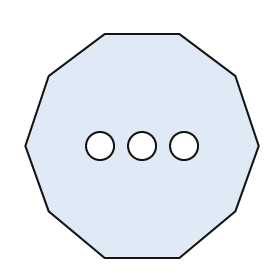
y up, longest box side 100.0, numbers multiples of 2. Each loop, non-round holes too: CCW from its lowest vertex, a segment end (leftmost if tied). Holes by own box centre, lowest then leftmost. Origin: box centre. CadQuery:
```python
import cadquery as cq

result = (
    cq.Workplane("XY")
    .moveTo(-16.0, -48.0)
    .lineTo(16.0, -48.0)
    .lineTo(40.0, -28.0)
    .lineTo(50.0, 0.0)
    .lineTo(40.0, 30.0)
    .lineTo(16.0, 48.0)
    .lineTo(-16.0, 48.0)
    .lineTo(-40.0, 30.0)
    .lineTo(-50.0, 0.0)
    .lineTo(-40.0, -28.0)
    .close()
    .moveTo(-18.0, 0.0)
    .circle(6.0)
    .moveTo(0.0, 0.0)
    .circle(6.0)
    .moveTo(18.0, 0.0)
    .circle(6.0)
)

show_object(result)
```